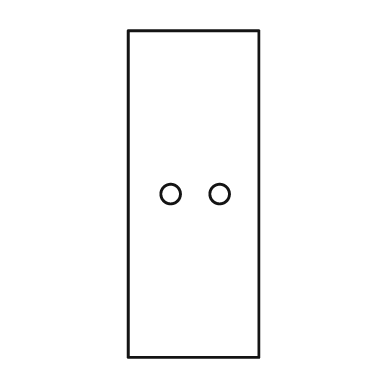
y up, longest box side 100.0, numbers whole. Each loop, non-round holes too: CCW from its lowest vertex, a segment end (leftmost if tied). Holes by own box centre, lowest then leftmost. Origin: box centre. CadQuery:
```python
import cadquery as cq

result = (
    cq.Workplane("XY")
    .moveTo(-20.0, -50.0)
    .lineTo(20.0, -50.0)
    .lineTo(20.0, 50.0)
    .lineTo(-20.0, 50.0)
    .close()
    .moveTo(-7.0, 0.0)
    .circle(3.0)
    .moveTo(8.0, 0.0)
    .circle(3.0)
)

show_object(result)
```